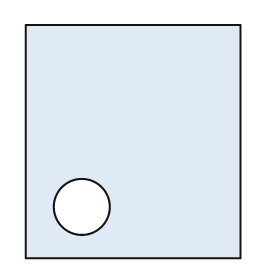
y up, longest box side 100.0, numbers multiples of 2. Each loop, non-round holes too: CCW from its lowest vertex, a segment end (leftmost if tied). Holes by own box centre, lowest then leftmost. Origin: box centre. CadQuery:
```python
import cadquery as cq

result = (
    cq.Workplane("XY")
    .moveTo(-46.0, -50.0)
    .lineTo(46.0, -50.0)
    .lineTo(46.0, 50.0)
    .lineTo(-46.0, 50.0)
    .close()
    .moveTo(-22.0, -28.0)
    .circle(12.0)
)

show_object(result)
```